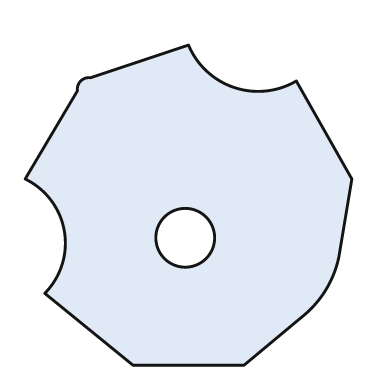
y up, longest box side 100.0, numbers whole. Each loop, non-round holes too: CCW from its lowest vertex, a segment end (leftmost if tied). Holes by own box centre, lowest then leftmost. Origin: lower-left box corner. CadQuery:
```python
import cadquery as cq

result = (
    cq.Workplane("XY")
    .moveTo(33.0, 0.0)
    .lineTo(67.0, 0.0)
    .lineTo(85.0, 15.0)
    .threePointArc((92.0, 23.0), (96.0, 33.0))
    .lineTo(100.0, 57.0)
    .lineTo(83.0, 87.0)
    .threePointArc((64.0, 85.0), (50.0, 98.0))
    .lineTo(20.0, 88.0)
    .threePointArc((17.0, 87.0), (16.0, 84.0))
    .lineTo(0.0, 57.0)
    .threePointArc((12.0, 41.0), (6.0, 22.0))
    .close()
    .moveTo(49.0, 39.0)
    .circle(9.0)
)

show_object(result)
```